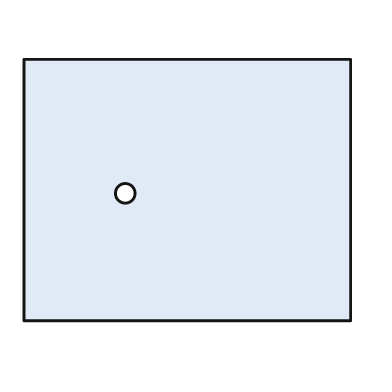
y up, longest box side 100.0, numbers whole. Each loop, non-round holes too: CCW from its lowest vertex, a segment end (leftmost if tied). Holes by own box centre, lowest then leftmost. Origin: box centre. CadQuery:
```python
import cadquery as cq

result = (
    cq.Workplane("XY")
    .moveTo(-50.0, -40.0)
    .lineTo(50.0, -40.0)
    .lineTo(50.0, 40.0)
    .lineTo(-50.0, 40.0)
    .close()
    .moveTo(-19.0, -1.0)
    .circle(3.0)
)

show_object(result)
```